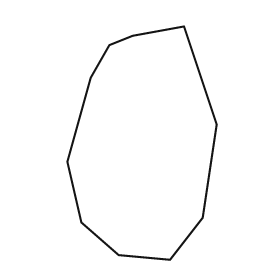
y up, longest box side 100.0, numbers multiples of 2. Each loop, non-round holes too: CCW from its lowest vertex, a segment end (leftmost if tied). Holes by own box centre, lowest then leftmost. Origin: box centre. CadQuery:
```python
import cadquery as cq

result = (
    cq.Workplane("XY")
    .moveTo(12.0, -50.0)
    .lineTo(26.0, -32.0)
    .lineTo(32.0, 8.0)
    .lineTo(18.0, 50.0)
    .lineTo(-4.0, 46.0)
    .lineTo(-14.0, 42.0)
    .lineTo(-22.0, 28.0)
    .lineTo(-32.0, -8.0)
    .lineTo(-26.0, -34.0)
    .lineTo(-10.0, -48.0)
    .close()
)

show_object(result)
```